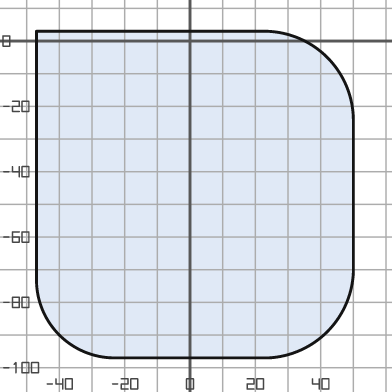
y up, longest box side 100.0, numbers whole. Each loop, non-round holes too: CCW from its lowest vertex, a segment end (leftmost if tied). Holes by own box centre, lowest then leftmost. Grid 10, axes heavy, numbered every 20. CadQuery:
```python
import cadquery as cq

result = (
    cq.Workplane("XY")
    .moveTo(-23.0, -97.0)
    .lineTo(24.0, -97.0)
    .threePointArc((42.0, -89.0), (50.0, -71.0))
    .lineTo(50.0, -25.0)
    .threePointArc((42.0, -5.0), (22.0, 3.0))
    .lineTo(-47.0, 3.0)
    .lineTo(-47.0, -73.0)
    .threePointArc((-40.0, -90.0), (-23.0, -97.0))
    .close()
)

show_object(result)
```